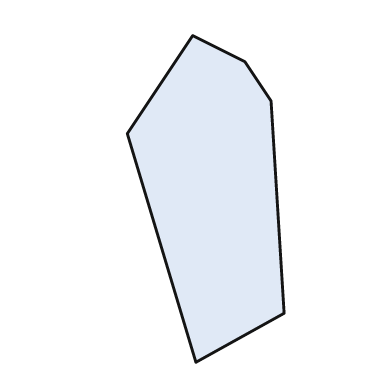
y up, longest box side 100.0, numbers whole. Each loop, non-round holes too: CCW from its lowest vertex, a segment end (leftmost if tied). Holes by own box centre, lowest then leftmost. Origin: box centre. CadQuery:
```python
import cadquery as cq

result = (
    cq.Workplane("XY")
    .moveTo(-3.0, -50.0)
    .lineTo(24.0, -35.0)
    .lineTo(20.0, 30.0)
    .lineTo(12.0, 42.0)
    .lineTo(-4.0, 50.0)
    .lineTo(-24.0, 20.0)
    .close()
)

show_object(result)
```